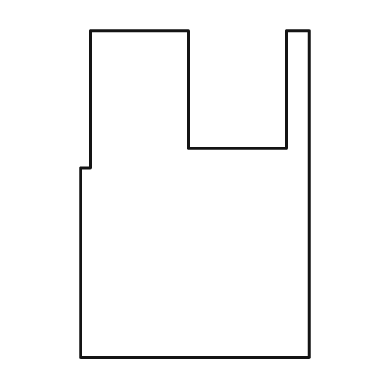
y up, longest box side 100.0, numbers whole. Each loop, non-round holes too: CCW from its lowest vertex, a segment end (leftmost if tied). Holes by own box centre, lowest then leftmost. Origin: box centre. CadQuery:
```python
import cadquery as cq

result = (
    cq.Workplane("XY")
    .moveTo(-35.0, -50.0)
    .lineTo(35.0, -50.0)
    .lineTo(35.0, 50.0)
    .lineTo(28.0, 50.0)
    .lineTo(28.0, 14.0)
    .lineTo(-2.0, 14.0)
    .lineTo(-2.0, 50.0)
    .lineTo(-32.0, 50.0)
    .lineTo(-32.0, 8.0)
    .lineTo(-35.0, 8.0)
    .close()
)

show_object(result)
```